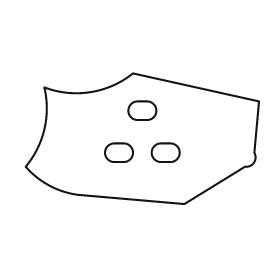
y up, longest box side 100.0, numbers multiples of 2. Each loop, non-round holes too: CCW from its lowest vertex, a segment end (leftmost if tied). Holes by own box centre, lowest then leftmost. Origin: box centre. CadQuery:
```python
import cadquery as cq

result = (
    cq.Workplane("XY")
    .moveTo(18.0, -28.0)
    .lineTo(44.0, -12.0)
    .threePointArc((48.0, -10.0), (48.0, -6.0))
    .lineTo(50.0, 16.0)
    .lineTo(-4.0, 28.0)
    .threePointArc((-22.0, 20.0), (-42.0, 22.0))
    .threePointArc((-42.0, 4.0), (-50.0, -12.0))
    .threePointArc((-40.0, -20.0), (-28.0, -24.0))
    .close()
    .moveTo(-12.0, -10.0)
    .lineTo(-8.0, -10.0)
    .threePointArc((-4.0, -6.0), (-8.0, -2.0))
    .lineTo(-12.0, -2.0)
    .threePointArc((-16.0, -6.0), (-12.0, -10.0))
    .close()
    .moveTo(8.0, -10.0)
    .lineTo(12.0, -10.0)
    .threePointArc((16.0, -6.0), (12.0, -2.0))
    .lineTo(8.0, -2.0)
    .threePointArc((4.0, -6.0), (8.0, -10.0))
    .close()
    .moveTo(-2.0, 8.0)
    .lineTo(2.0, 8.0)
    .threePointArc((6.0, 12.0), (2.0, 16.0))
    .lineTo(-2.0, 16.0)
    .threePointArc((-6.0, 12.0), (-2.0, 8.0))
    .close()
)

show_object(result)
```